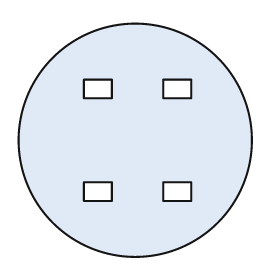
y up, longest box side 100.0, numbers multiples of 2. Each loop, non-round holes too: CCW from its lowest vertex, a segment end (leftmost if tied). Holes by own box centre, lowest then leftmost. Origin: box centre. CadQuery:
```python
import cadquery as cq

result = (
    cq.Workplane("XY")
    .moveTo(0.0, 0.0)
    .circle(50.0)
    .moveTo(-22.0, -26.0)
    .lineTo(-10.0, -26.0)
    .lineTo(-10.0, -18.0)
    .lineTo(-22.0, -18.0)
    .close()
    .moveTo(12.0, -26.0)
    .lineTo(24.0, -26.0)
    .lineTo(24.0, -18.0)
    .lineTo(12.0, -18.0)
    .close()
    .moveTo(-22.0, 18.0)
    .lineTo(-10.0, 18.0)
    .lineTo(-10.0, 26.0)
    .lineTo(-22.0, 26.0)
    .close()
    .moveTo(12.0, 18.0)
    .lineTo(24.0, 18.0)
    .lineTo(24.0, 26.0)
    .lineTo(12.0, 26.0)
    .close()
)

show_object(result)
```